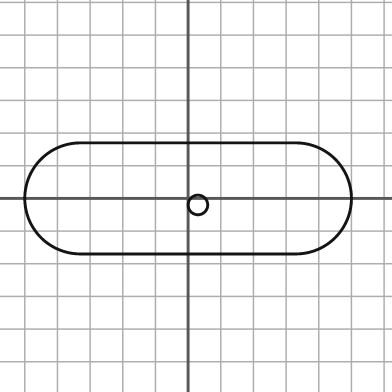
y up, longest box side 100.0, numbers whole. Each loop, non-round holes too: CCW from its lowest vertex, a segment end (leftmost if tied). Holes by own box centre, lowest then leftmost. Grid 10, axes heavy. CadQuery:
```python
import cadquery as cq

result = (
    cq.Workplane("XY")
    .moveTo(-33.0, -17.0)
    .lineTo(33.0, -17.0)
    .threePointArc((50.0, 0.0), (33.0, 17.0))
    .lineTo(-33.0, 17.0)
    .threePointArc((-50.0, 0.0), (-33.0, -17.0))
    .close()
    .moveTo(3.0, -2.0)
    .circle(3.0)
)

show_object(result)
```